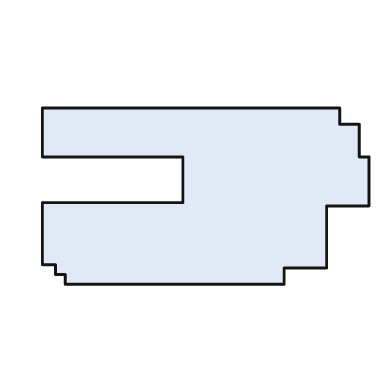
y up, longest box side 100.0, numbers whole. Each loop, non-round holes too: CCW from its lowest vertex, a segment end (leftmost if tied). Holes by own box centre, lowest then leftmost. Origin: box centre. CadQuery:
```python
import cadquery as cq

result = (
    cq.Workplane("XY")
    .moveTo(-43.0, -27.0)
    .lineTo(24.0, -27.0)
    .lineTo(24.0, -22.0)
    .lineTo(37.0, -22.0)
    .lineTo(37.0, -3.0)
    .lineTo(50.0, -3.0)
    .lineTo(50.0, 12.0)
    .lineTo(47.0, 12.0)
    .lineTo(47.0, 22.0)
    .lineTo(41.0, 22.0)
    .lineTo(41.0, 27.0)
    .lineTo(-50.0, 27.0)
    .lineTo(-50.0, 12.0)
    .lineTo(-7.0, 12.0)
    .lineTo(-7.0, -2.0)
    .lineTo(-50.0, -2.0)
    .lineTo(-50.0, -21.0)
    .lineTo(-46.0, -21.0)
    .lineTo(-46.0, -24.0)
    .lineTo(-43.0, -24.0)
    .close()
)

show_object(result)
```